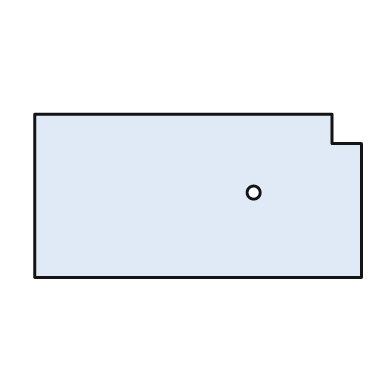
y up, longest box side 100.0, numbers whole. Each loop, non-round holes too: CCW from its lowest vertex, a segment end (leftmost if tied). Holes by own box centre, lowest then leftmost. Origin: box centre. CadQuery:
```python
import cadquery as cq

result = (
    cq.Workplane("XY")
    .moveTo(-50.0, -25.0)
    .lineTo(50.0, -25.0)
    .lineTo(50.0, 16.0)
    .lineTo(41.0, 16.0)
    .lineTo(41.0, 25.0)
    .lineTo(-50.0, 25.0)
    .close()
    .moveTo(17.0, 1.0)
    .circle(2.0)
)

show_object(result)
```